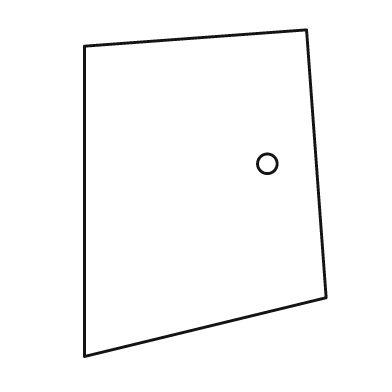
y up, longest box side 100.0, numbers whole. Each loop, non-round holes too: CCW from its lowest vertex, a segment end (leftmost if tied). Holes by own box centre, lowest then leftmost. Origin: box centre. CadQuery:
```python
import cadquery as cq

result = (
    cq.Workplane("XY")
    .moveTo(-37.0, -50.0)
    .lineTo(37.0, -32.0)
    .lineTo(31.0, 50.0)
    .lineTo(-37.0, 45.0)
    .close()
    .moveTo(19.0, 9.0)
    .circle(3.0)
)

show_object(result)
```